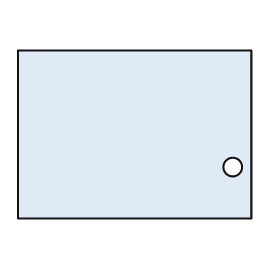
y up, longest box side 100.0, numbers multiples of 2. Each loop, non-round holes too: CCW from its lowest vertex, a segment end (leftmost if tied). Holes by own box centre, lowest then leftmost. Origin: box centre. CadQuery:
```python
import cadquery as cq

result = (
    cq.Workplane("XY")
    .moveTo(-50.0, -36.0)
    .lineTo(50.0, -36.0)
    .lineTo(50.0, 36.0)
    .lineTo(-50.0, 36.0)
    .close()
    .moveTo(42.0, -14.0)
    .circle(4.0)
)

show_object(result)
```